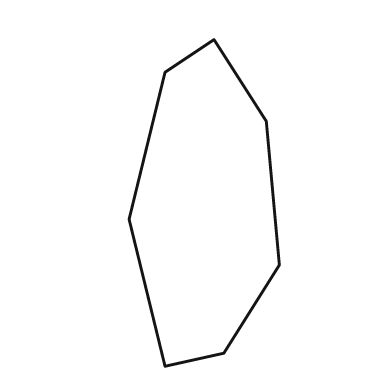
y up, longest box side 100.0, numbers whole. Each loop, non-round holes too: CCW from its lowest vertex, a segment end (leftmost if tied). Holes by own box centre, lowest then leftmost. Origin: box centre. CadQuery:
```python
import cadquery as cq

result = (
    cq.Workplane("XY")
    .moveTo(-12.0, -50.0)
    .lineTo(6.0, -46.0)
    .lineTo(23.0, -19.0)
    .lineTo(19.0, 25.0)
    .lineTo(3.0, 50.0)
    .lineTo(-12.0, 40.0)
    .lineTo(-23.0, -5.0)
    .close()
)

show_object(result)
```